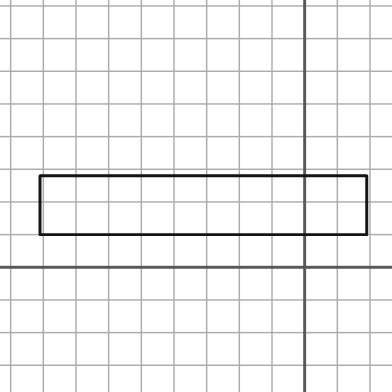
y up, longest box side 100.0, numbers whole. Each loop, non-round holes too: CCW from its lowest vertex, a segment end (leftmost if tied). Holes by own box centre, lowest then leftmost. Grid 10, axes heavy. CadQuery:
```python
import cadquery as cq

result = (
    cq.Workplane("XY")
    .moveTo(-81.0, 10.0)
    .lineTo(19.0, 10.0)
    .lineTo(19.0, 28.0)
    .lineTo(-81.0, 28.0)
    .close()
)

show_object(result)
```